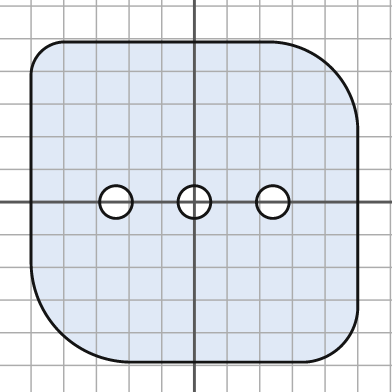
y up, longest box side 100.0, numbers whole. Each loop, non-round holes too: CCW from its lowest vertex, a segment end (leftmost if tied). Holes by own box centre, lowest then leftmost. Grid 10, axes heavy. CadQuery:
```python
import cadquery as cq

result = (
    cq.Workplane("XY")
    .moveTo(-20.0, -49.0)
    .lineTo(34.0, -49.0)
    .threePointArc((45.0, -44.0), (50.0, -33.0))
    .lineTo(50.0, 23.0)
    .threePointArc((42.0, 41.0), (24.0, 49.0))
    .lineTo(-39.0, 49.0)
    .threePointArc((-47.0, 46.0), (-50.0, 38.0))
    .lineTo(-50.0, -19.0)
    .threePointArc((-41.0, -40.0), (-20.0, -49.0))
    .close()
    .moveTo(-24.0, 0.0)
    .circle(5.0)
    .moveTo(0.0, 0.0)
    .circle(5.0)
    .moveTo(24.0, 0.0)
    .circle(5.0)
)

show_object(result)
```